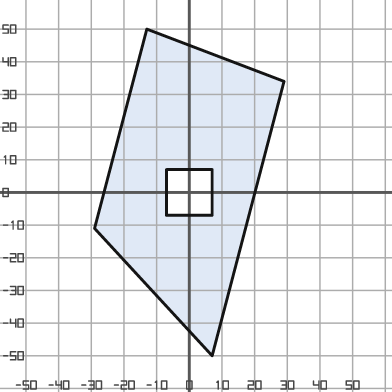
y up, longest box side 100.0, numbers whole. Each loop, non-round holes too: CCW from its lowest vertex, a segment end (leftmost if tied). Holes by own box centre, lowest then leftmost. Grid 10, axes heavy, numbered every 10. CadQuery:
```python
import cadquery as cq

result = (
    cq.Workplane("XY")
    .moveTo(7.0, -50.0)
    .lineTo(29.0, 34.0)
    .lineTo(-13.0, 50.0)
    .lineTo(-29.0, -11.0)
    .close()
    .moveTo(-7.0, -7.0)
    .lineTo(7.0, -7.0)
    .lineTo(7.0, 7.0)
    .lineTo(-7.0, 7.0)
    .close()
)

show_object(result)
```